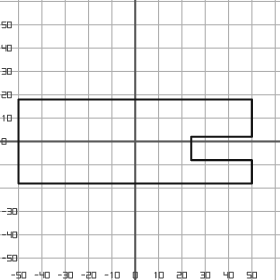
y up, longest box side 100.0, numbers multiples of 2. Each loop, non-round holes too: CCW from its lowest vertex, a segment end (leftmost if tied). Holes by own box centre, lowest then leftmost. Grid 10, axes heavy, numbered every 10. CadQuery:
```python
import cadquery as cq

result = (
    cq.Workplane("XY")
    .moveTo(-50.0, -18.0)
    .lineTo(50.0, -18.0)
    .lineTo(50.0, -8.0)
    .lineTo(24.0, -8.0)
    .lineTo(24.0, 2.0)
    .lineTo(50.0, 2.0)
    .lineTo(50.0, 18.0)
    .lineTo(-50.0, 18.0)
    .close()
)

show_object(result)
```